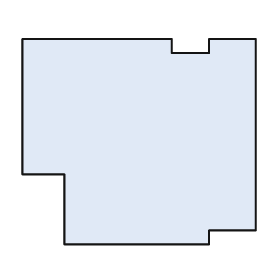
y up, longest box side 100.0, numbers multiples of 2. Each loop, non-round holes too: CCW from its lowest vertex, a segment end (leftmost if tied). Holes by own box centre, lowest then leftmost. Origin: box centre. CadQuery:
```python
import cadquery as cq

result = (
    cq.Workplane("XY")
    .moveTo(-32.0, -44.0)
    .lineTo(30.0, -44.0)
    .lineTo(30.0, -38.0)
    .lineTo(50.0, -38.0)
    .lineTo(50.0, 44.0)
    .lineTo(30.0, 44.0)
    .lineTo(30.0, 38.0)
    .lineTo(14.0, 38.0)
    .lineTo(14.0, 44.0)
    .lineTo(-50.0, 44.0)
    .lineTo(-50.0, -14.0)
    .lineTo(-32.0, -14.0)
    .close()
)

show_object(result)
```